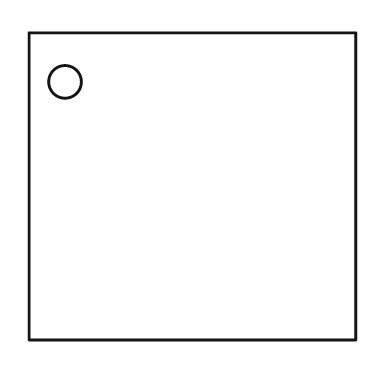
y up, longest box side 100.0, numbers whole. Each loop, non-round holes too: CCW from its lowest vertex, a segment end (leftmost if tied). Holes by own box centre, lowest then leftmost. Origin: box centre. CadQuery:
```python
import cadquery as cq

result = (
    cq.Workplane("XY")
    .moveTo(-50.0, -47.0)
    .lineTo(50.0, -47.0)
    .lineTo(50.0, 47.0)
    .lineTo(-50.0, 47.0)
    .close()
    .moveTo(-39.0, 32.0)
    .circle(5.0)
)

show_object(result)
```